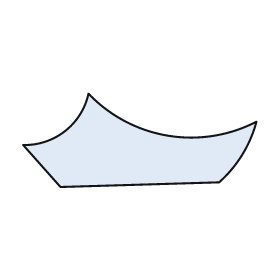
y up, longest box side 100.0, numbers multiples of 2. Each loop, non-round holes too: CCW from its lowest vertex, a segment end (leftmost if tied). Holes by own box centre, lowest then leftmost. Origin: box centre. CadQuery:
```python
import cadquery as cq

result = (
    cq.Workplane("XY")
    .moveTo(-34.0, -20.0)
    .lineTo(34.0, -18.0)
    .threePointArc((44.0, -6.0), (50.0, 8.0))
    .threePointArc((12.0, 2.0), (-22.0, 20.0))
    .threePointArc((-32.0, 4.0), (-50.0, -2.0))
    .close()
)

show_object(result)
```